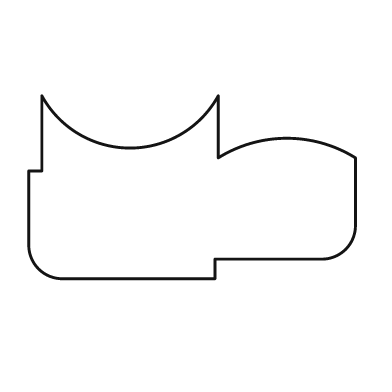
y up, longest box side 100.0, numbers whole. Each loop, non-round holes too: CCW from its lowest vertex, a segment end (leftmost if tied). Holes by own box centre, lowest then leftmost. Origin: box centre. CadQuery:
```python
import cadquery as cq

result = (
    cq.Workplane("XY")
    .moveTo(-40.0, -28.0)
    .lineTo(7.0, -28.0)
    .lineTo(7.0, -22.0)
    .lineTo(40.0, -22.0)
    .threePointArc((47.0, -19.0), (50.0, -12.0))
    .lineTo(50.0, 9.0)
    .threePointArc((29.0, 15.0), (8.0, 9.0))
    .lineTo(8.0, 28.0)
    .threePointArc((-19.0, 12.0), (-46.0, 28.0))
    .lineTo(-46.0, 5.0)
    .lineTo(-50.0, 5.0)
    .lineTo(-50.0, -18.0)
    .threePointArc((-47.0, -25.0), (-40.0, -28.0))
    .close()
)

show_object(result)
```